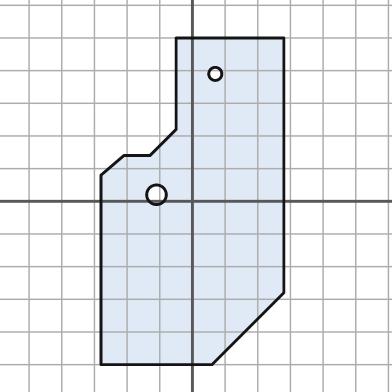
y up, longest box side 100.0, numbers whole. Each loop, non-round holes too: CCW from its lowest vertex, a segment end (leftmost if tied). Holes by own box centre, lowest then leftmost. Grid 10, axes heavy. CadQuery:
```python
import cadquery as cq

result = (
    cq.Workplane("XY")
    .moveTo(-28.0, -50.0)
    .lineTo(6.0, -50.0)
    .lineTo(28.0, -28.0)
    .lineTo(28.0, 50.0)
    .lineTo(-5.0, 50.0)
    .lineTo(-5.0, 22.0)
    .lineTo(-13.0, 14.0)
    .lineTo(-21.0, 14.0)
    .lineTo(-28.0, 8.0)
    .close()
    .moveTo(-11.0, 2.0)
    .circle(3.0)
    .moveTo(7.0, 39.0)
    .circle(2.0)
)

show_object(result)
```